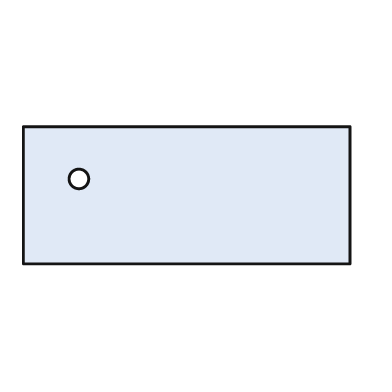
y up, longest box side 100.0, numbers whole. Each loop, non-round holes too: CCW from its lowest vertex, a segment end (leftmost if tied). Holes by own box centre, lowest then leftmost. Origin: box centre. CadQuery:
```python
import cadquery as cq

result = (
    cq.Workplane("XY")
    .moveTo(-50.0, -21.0)
    .lineTo(50.0, -21.0)
    .lineTo(50.0, 21.0)
    .lineTo(-50.0, 21.0)
    .close()
    .moveTo(-33.0, 5.0)
    .circle(3.0)
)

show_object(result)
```